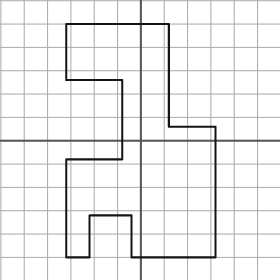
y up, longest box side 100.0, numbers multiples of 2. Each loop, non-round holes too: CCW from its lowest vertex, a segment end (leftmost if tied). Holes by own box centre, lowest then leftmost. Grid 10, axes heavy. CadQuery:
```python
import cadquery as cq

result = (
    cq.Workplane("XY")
    .moveTo(-32.0, -50.0)
    .lineTo(-22.0, -50.0)
    .lineTo(-22.0, -32.0)
    .lineTo(-4.0, -32.0)
    .lineTo(-4.0, -50.0)
    .lineTo(32.0, -50.0)
    .lineTo(32.0, 6.0)
    .lineTo(12.0, 6.0)
    .lineTo(12.0, 50.0)
    .lineTo(-32.0, 50.0)
    .lineTo(-32.0, 26.0)
    .lineTo(-8.0, 26.0)
    .lineTo(-8.0, -8.0)
    .lineTo(-32.0, -8.0)
    .close()
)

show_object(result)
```